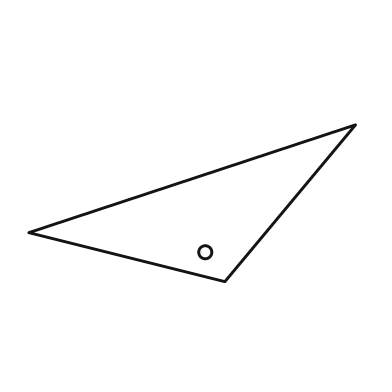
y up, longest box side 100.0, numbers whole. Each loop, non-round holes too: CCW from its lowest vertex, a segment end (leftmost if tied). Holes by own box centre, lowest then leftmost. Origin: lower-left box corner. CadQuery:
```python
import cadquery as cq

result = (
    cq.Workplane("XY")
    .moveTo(60.0, 0.0)
    .lineTo(100.0, 48.0)
    .lineTo(0.0, 15.0)
    .close()
    .moveTo(54.0, 9.0)
    .circle(2.0)
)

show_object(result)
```